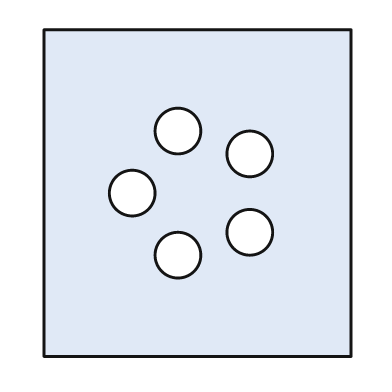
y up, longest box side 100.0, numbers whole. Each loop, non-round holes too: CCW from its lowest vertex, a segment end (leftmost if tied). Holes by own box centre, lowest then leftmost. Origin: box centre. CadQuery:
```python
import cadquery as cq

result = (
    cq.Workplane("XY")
    .moveTo(-47.0, -50.0)
    .lineTo(47.0, -50.0)
    .lineTo(47.0, 50.0)
    .lineTo(-47.0, 50.0)
    .close()
    .moveTo(-6.0, -19.0)
    .circle(7.0)
    .moveTo(16.0, -12.0)
    .circle(7.0)
    .moveTo(-20.0, 0.0)
    .circle(7.0)
    .moveTo(16.0, 12.0)
    .circle(7.0)
    .moveTo(-6.0, 19.0)
    .circle(7.0)
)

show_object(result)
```